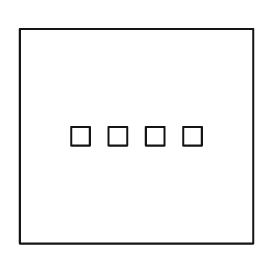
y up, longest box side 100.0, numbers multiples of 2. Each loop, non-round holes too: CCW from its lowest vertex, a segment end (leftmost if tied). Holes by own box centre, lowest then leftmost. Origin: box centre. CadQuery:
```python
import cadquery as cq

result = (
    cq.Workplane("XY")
    .moveTo(-50.0, -46.0)
    .lineTo(50.0, -46.0)
    .lineTo(50.0, 46.0)
    .lineTo(-50.0, 46.0)
    .close()
    .moveTo(-28.0, -4.0)
    .lineTo(-20.0, -4.0)
    .lineTo(-20.0, 4.0)
    .lineTo(-28.0, 4.0)
    .close()
    .moveTo(-12.0, -4.0)
    .lineTo(-4.0, -4.0)
    .lineTo(-4.0, 4.0)
    .lineTo(-12.0, 4.0)
    .close()
    .moveTo(4.0, -4.0)
    .lineTo(12.0, -4.0)
    .lineTo(12.0, 4.0)
    .lineTo(4.0, 4.0)
    .close()
    .moveTo(20.0, -4.0)
    .lineTo(28.0, -4.0)
    .lineTo(28.0, 4.0)
    .lineTo(20.0, 4.0)
    .close()
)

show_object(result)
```